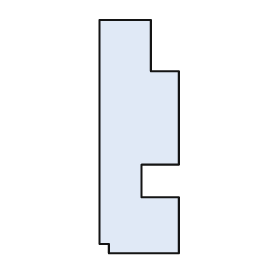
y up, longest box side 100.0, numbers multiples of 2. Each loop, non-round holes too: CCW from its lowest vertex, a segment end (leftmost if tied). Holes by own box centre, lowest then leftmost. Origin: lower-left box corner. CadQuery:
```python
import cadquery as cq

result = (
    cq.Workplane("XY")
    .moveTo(4.0, 0.0)
    .lineTo(34.0, 0.0)
    .lineTo(34.0, 24.0)
    .lineTo(18.0, 24.0)
    .lineTo(18.0, 38.0)
    .lineTo(34.0, 38.0)
    .lineTo(34.0, 78.0)
    .lineTo(22.0, 78.0)
    .lineTo(22.0, 100.0)
    .lineTo(0.0, 100.0)
    .lineTo(0.0, 4.0)
    .lineTo(4.0, 4.0)
    .close()
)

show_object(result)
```